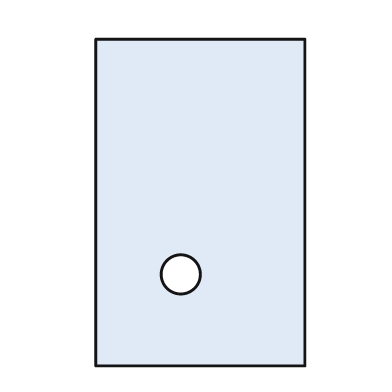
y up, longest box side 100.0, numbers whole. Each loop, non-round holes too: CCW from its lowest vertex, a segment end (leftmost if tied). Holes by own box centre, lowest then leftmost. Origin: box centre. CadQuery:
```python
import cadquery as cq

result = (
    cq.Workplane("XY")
    .moveTo(-32.0, -50.0)
    .lineTo(32.0, -50.0)
    .lineTo(32.0, 50.0)
    .lineTo(-32.0, 50.0)
    .close()
    .moveTo(-6.0, -22.0)
    .circle(6.0)
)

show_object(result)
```